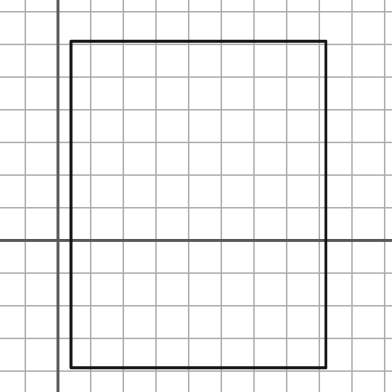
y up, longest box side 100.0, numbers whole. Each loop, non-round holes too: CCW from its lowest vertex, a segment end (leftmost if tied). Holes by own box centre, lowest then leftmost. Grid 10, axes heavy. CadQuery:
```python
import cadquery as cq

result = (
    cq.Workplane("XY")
    .moveTo(4.0, -39.0)
    .lineTo(82.0, -39.0)
    .lineTo(82.0, 61.0)
    .lineTo(4.0, 61.0)
    .close()
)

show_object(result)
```